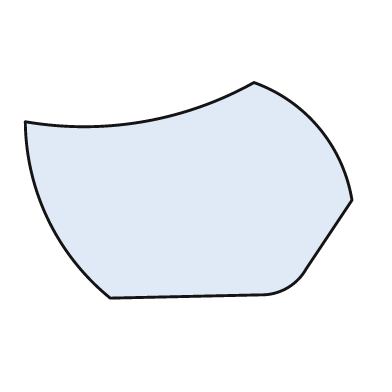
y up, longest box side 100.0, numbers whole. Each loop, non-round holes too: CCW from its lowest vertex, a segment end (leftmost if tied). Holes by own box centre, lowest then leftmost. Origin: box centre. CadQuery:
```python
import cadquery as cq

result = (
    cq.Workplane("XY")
    .moveTo(-24.0, -33.0)
    .lineTo(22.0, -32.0)
    .threePointArc((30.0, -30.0), (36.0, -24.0))
    .lineTo(50.0, -3.0)
    .threePointArc((40.0, 19.0), (20.0, 33.0))
    .threePointArc((-14.0, 21.0), (-50.0, 21.0))
    .threePointArc((-43.0, -9.0), (-24.0, -33.0))
    .close()
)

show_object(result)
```